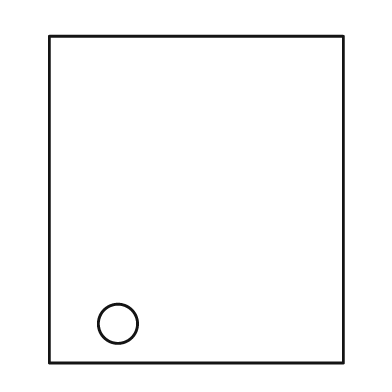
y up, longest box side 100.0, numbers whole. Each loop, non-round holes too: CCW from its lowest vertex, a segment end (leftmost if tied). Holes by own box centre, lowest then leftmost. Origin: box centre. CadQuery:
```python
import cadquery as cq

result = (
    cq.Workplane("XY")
    .moveTo(-45.0, -50.0)
    .lineTo(45.0, -50.0)
    .lineTo(45.0, 50.0)
    .lineTo(-45.0, 50.0)
    .close()
    .moveTo(-24.0, -38.0)
    .circle(6.0)
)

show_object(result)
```